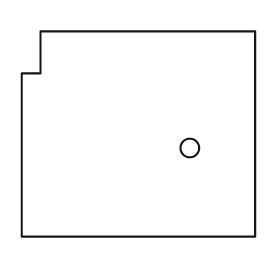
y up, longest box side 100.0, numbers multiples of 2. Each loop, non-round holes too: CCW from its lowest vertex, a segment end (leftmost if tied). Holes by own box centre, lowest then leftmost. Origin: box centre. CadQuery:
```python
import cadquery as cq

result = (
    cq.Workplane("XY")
    .moveTo(-50.0, -44.0)
    .lineTo(50.0, -44.0)
    .lineTo(50.0, 44.0)
    .lineTo(-42.0, 44.0)
    .lineTo(-42.0, 26.0)
    .lineTo(-50.0, 26.0)
    .close()
    .moveTo(22.0, -6.0)
    .circle(4.0)
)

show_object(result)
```